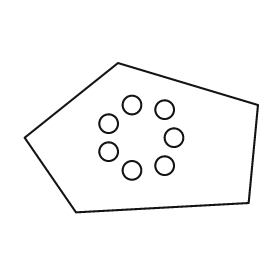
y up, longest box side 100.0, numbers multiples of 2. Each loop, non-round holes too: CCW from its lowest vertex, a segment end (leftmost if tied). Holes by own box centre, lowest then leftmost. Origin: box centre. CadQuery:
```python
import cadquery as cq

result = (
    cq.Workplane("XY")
    .moveTo(-28.0, -32.0)
    .lineTo(46.0, -28.0)
    .lineTo(50.0, 14.0)
    .lineTo(-10.0, 32.0)
    .lineTo(-50.0, 0.0)
    .close()
    .moveTo(-4.0, -14.0)
    .circle(4.0)
    .moveTo(10.0, -12.0)
    .circle(4.0)
    .moveTo(-14.0, -6.0)
    .circle(4.0)
    .moveTo(14.0, 0.0)
    .circle(4.0)
    .moveTo(-14.0, 6.0)
    .circle(4.0)
    .moveTo(10.0, 12.0)
    .circle(4.0)
    .moveTo(-4.0, 14.0)
    .circle(4.0)
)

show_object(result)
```